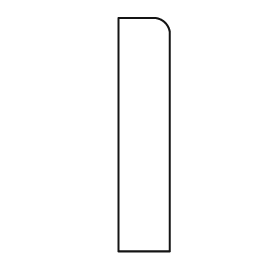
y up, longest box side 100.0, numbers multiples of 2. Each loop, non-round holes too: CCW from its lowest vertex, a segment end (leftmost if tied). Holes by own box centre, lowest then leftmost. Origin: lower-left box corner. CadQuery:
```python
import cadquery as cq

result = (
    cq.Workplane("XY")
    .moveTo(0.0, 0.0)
    .lineTo(22.0, 0.0)
    .lineTo(22.0, 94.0)
    .threePointArc((20.0, 98.0), (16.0, 100.0))
    .lineTo(0.0, 100.0)
    .close()
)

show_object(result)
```